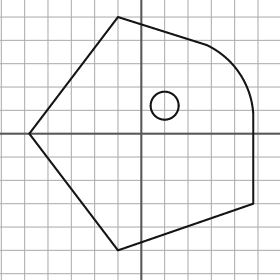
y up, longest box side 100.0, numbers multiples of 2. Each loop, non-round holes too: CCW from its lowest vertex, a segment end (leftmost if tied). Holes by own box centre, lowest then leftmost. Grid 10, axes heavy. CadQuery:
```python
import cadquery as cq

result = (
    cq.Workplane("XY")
    .moveTo(-10.0, -50.0)
    .lineTo(48.0, -30.0)
    .lineTo(48.0, 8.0)
    .threePointArc((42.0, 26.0), (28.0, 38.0))
    .lineTo(-10.0, 50.0)
    .lineTo(-48.0, 0.0)
    .close()
    .moveTo(10.0, 12.0)
    .circle(6.0)
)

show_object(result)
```